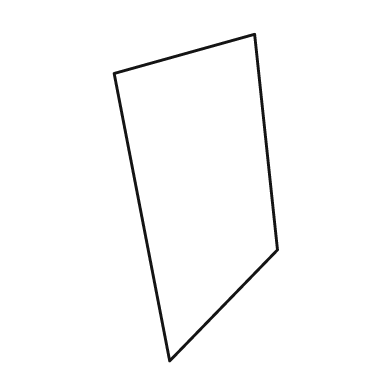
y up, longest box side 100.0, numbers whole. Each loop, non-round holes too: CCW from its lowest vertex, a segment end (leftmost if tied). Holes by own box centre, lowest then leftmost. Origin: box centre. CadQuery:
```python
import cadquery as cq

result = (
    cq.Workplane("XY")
    .moveTo(-8.0, -50.0)
    .lineTo(25.0, -16.0)
    .lineTo(18.0, 50.0)
    .lineTo(-25.0, 38.0)
    .close()
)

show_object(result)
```